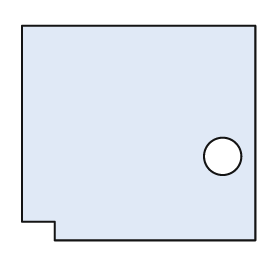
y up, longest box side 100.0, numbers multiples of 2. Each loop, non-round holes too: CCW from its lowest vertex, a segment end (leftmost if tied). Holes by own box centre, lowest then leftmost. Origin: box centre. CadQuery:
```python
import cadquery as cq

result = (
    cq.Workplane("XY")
    .moveTo(-36.0, -46.0)
    .lineTo(50.0, -46.0)
    .lineTo(50.0, 46.0)
    .lineTo(-50.0, 46.0)
    .lineTo(-50.0, -38.0)
    .lineTo(-36.0, -38.0)
    .close()
    .moveTo(36.0, -10.0)
    .circle(8.0)
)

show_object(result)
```